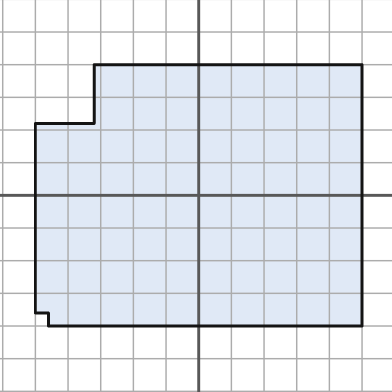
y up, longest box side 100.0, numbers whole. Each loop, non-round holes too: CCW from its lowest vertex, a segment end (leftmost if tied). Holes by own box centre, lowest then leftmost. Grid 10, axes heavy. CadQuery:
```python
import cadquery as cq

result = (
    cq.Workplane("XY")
    .moveTo(-46.0, -40.0)
    .lineTo(50.0, -40.0)
    .lineTo(50.0, 40.0)
    .lineTo(-32.0, 40.0)
    .lineTo(-32.0, 22.0)
    .lineTo(-50.0, 22.0)
    .lineTo(-50.0, -36.0)
    .lineTo(-46.0, -36.0)
    .close()
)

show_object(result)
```